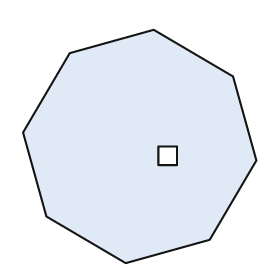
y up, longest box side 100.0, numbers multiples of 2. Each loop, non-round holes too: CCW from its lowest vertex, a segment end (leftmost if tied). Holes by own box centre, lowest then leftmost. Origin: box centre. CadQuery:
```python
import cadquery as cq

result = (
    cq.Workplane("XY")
    .moveTo(-6.0, -50.0)
    .lineTo(30.0, -40.0)
    .lineTo(50.0, -6.0)
    .lineTo(40.0, 30.0)
    .lineTo(6.0, 50.0)
    .lineTo(-30.0, 40.0)
    .lineTo(-50.0, 6.0)
    .lineTo(-40.0, -30.0)
    .close()
    .moveTo(8.0, -8.0)
    .lineTo(16.0, -8.0)
    .lineTo(16.0, 0.0)
    .lineTo(8.0, 0.0)
    .close()
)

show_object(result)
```